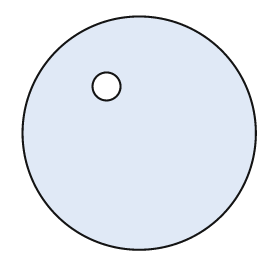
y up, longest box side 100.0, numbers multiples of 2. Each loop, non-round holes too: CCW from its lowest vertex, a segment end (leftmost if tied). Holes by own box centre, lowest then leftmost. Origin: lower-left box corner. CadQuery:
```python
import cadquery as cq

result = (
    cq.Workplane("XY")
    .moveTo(50.0, 50.0)
    .circle(50.0)
    .moveTo(36.0, 70.0)
    .circle(6.0)
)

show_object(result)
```